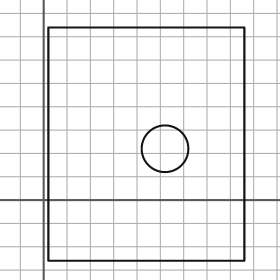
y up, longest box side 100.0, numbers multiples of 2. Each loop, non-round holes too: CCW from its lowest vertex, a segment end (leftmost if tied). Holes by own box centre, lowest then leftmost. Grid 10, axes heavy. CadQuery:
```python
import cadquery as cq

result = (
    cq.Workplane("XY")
    .moveTo(2.0, -26.0)
    .lineTo(86.0, -26.0)
    .lineTo(86.0, 74.0)
    .lineTo(2.0, 74.0)
    .close()
    .moveTo(52.0, 22.0)
    .circle(10.0)
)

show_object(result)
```